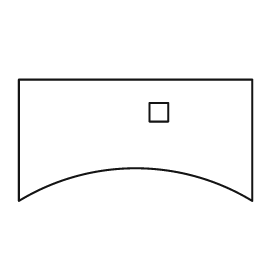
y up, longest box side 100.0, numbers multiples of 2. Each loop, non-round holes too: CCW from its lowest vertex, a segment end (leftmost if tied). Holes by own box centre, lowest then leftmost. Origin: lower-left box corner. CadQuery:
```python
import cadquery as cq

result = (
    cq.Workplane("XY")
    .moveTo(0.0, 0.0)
    .threePointArc((50.0, 14.0), (100.0, 0.0))
    .lineTo(100.0, 52.0)
    .lineTo(0.0, 52.0)
    .close()
    .moveTo(56.0, 34.0)
    .lineTo(64.0, 34.0)
    .lineTo(64.0, 42.0)
    .lineTo(56.0, 42.0)
    .close()
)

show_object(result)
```